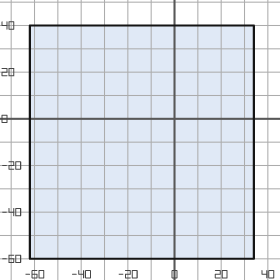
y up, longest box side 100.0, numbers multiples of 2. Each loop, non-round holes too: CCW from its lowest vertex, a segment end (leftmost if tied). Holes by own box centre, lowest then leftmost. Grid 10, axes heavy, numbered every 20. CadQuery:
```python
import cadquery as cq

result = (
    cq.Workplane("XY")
    .moveTo(-62.0, -60.0)
    .lineTo(34.0, -60.0)
    .lineTo(34.0, 40.0)
    .lineTo(-62.0, 40.0)
    .close()
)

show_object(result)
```